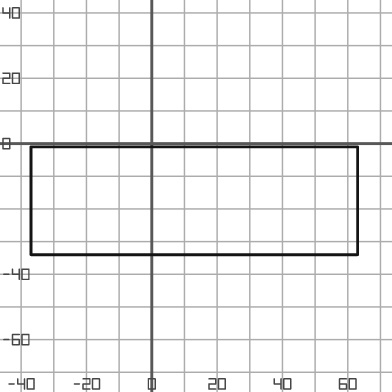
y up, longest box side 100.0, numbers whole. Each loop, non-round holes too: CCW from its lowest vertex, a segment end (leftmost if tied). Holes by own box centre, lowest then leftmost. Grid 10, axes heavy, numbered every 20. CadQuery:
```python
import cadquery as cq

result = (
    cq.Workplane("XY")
    .moveTo(-37.0, -34.0)
    .lineTo(63.0, -34.0)
    .lineTo(63.0, -1.0)
    .lineTo(-37.0, -1.0)
    .close()
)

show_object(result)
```